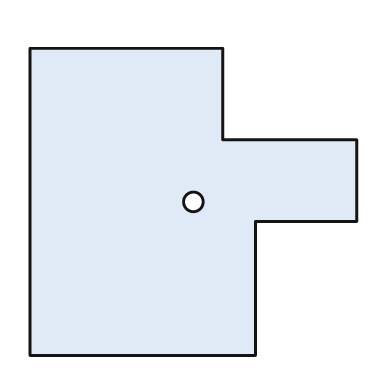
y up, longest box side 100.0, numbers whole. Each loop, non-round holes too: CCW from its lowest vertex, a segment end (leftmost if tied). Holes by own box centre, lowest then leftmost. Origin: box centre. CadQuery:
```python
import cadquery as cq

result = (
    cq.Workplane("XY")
    .moveTo(-50.0, -47.0)
    .lineTo(19.0, -47.0)
    .lineTo(19.0, -6.0)
    .lineTo(50.0, -6.0)
    .lineTo(50.0, 19.0)
    .lineTo(9.0, 19.0)
    .lineTo(9.0, 47.0)
    .lineTo(-50.0, 47.0)
    .close()
    .moveTo(0.0, 0.0)
    .circle(3.0)
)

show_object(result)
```